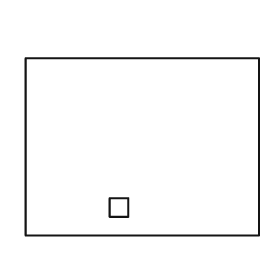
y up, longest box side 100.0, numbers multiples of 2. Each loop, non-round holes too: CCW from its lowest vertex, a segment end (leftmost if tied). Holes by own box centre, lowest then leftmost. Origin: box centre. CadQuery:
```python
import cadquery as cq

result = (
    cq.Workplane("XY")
    .moveTo(-50.0, -38.0)
    .lineTo(50.0, -38.0)
    .lineTo(50.0, 38.0)
    .lineTo(-50.0, 38.0)
    .close()
    .moveTo(-14.0, -30.0)
    .lineTo(-6.0, -30.0)
    .lineTo(-6.0, -22.0)
    .lineTo(-14.0, -22.0)
    .close()
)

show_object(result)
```